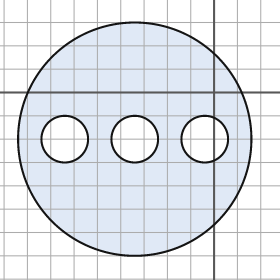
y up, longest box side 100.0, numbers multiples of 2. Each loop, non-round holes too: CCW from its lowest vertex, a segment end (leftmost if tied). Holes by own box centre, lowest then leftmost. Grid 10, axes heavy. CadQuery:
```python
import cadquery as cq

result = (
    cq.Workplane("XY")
    .moveTo(-34.0, -20.0)
    .circle(50.0)
    .moveTo(-64.0, -20.0)
    .circle(10.0)
    .moveTo(-34.0, -20.0)
    .circle(10.0)
    .moveTo(-4.0, -20.0)
    .circle(10.0)
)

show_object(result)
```